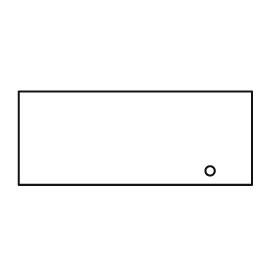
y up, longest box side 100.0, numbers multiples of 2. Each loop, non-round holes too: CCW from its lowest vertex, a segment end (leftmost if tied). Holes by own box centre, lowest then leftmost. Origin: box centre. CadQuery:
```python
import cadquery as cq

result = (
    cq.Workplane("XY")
    .moveTo(-50.0, -20.0)
    .lineTo(50.0, -20.0)
    .lineTo(50.0, 20.0)
    .lineTo(-50.0, 20.0)
    .close()
    .moveTo(32.0, -14.0)
    .circle(2.0)
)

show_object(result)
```